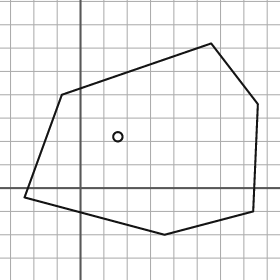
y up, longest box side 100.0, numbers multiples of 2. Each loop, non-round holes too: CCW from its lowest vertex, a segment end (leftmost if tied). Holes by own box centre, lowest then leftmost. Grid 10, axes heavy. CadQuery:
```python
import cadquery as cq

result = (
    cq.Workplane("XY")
    .moveTo(36.0, -20.0)
    .lineTo(74.0, -10.0)
    .lineTo(76.0, 36.0)
    .lineTo(56.0, 62.0)
    .lineTo(-8.0, 40.0)
    .lineTo(-24.0, -4.0)
    .close()
    .moveTo(16.0, 22.0)
    .circle(2.0)
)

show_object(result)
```